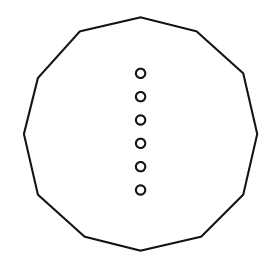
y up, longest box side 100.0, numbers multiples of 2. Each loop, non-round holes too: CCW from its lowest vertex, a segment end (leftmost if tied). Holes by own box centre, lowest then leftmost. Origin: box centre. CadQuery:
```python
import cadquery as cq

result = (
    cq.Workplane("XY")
    .moveTo(0.0, -50.0)
    .lineTo(26.0, -44.0)
    .lineTo(44.0, -26.0)
    .lineTo(50.0, 0.0)
    .lineTo(44.0, 26.0)
    .lineTo(24.0, 44.0)
    .lineTo(0.0, 50.0)
    .lineTo(-26.0, 44.0)
    .lineTo(-44.0, 24.0)
    .lineTo(-50.0, 0.0)
    .lineTo(-44.0, -26.0)
    .lineTo(-24.0, -44.0)
    .close()
    .moveTo(0.0, -24.0)
    .circle(2.0)
    .moveTo(0.0, -14.0)
    .circle(2.0)
    .moveTo(0.0, -4.0)
    .circle(2.0)
    .moveTo(0.0, 6.0)
    .circle(2.0)
    .moveTo(0.0, 16.0)
    .circle(2.0)
    .moveTo(0.0, 26.0)
    .circle(2.0)
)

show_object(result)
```